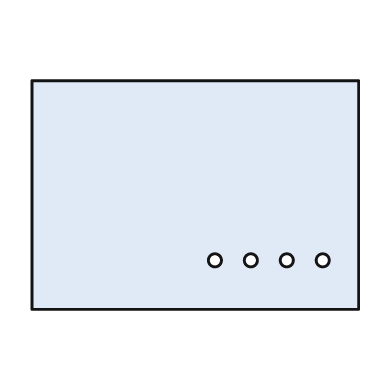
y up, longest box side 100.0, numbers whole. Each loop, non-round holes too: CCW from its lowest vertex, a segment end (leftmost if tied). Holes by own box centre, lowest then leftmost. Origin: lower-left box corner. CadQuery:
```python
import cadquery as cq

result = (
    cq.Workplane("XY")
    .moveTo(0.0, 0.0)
    .lineTo(100.0, 0.0)
    .lineTo(100.0, 70.0)
    .lineTo(0.0, 70.0)
    .close()
    .moveTo(56.0, 15.0)
    .circle(2.0)
    .moveTo(67.0, 15.0)
    .circle(2.0)
    .moveTo(78.0, 15.0)
    .circle(2.0)
    .moveTo(89.0, 15.0)
    .circle(2.0)
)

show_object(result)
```